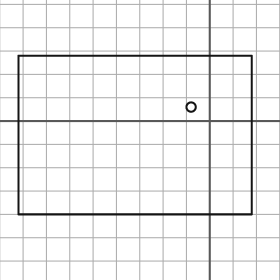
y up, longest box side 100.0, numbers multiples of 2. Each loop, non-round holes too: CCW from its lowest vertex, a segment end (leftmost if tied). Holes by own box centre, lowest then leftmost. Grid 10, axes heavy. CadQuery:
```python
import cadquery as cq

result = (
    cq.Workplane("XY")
    .moveTo(-82.0, -40.0)
    .lineTo(18.0, -40.0)
    .lineTo(18.0, 28.0)
    .lineTo(-82.0, 28.0)
    .close()
    .moveTo(-8.0, 6.0)
    .circle(2.0)
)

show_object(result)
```